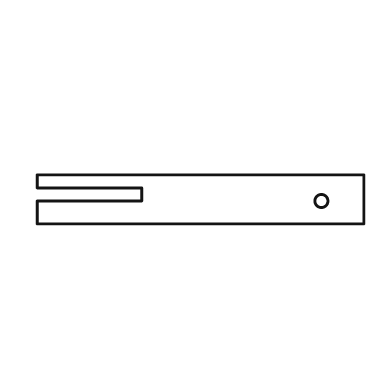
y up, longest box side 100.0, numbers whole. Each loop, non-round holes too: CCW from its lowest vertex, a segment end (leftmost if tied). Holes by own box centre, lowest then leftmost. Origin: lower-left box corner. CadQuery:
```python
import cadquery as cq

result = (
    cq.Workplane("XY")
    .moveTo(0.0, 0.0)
    .lineTo(100.0, 0.0)
    .lineTo(100.0, 15.0)
    .lineTo(0.0, 15.0)
    .lineTo(0.0, 11.0)
    .lineTo(32.0, 11.0)
    .lineTo(32.0, 7.0)
    .lineTo(0.0, 7.0)
    .close()
    .moveTo(87.0, 7.0)
    .circle(2.0)
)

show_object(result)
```